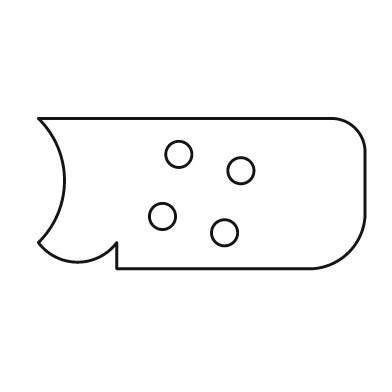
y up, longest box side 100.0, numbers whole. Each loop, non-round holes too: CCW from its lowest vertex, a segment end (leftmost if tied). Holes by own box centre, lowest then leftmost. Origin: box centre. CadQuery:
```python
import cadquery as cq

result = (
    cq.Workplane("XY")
    .moveTo(-26.0, -23.0)
    .lineTo(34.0, -23.0)
    .threePointArc((45.0, -18.0), (50.0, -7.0))
    .lineTo(50.0, 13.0)
    .threePointArc((47.0, 20.0), (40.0, 23.0))
    .lineTo(-50.0, 23.0)
    .threePointArc((-42.0, 4.0), (-50.0, -15.0))
    .threePointArc((-38.0, -21.0), (-26.0, -15.0))
    .close()
    .moveTo(7.0, -12.0)
    .circle(4.0)
    .moveTo(-12.0, -7.0)
    .circle(4.0)
    .moveTo(12.0, 7.0)
    .circle(4.0)
    .moveTo(-7.0, 12.0)
    .circle(4.0)
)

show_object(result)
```